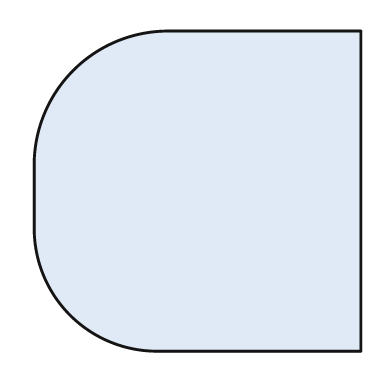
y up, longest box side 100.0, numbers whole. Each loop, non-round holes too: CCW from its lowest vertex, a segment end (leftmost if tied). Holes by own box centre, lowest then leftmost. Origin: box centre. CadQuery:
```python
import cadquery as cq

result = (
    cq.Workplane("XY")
    .moveTo(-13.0, -49.0)
    .lineTo(50.0, -49.0)
    .lineTo(50.0, 49.0)
    .lineTo(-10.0, 49.0)
    .threePointArc((-38.0, 37.0), (-50.0, 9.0))
    .lineTo(-50.0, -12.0)
    .threePointArc((-39.0, -38.0), (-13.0, -49.0))
    .close()
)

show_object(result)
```